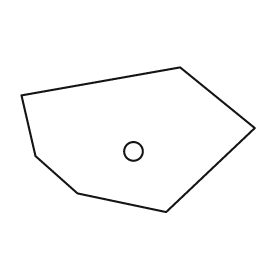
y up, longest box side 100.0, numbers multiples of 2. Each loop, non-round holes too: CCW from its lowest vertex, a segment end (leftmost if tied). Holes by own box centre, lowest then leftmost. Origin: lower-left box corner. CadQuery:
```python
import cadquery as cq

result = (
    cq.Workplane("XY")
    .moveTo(62.0, 0.0)
    .lineTo(100.0, 36.0)
    .lineTo(68.0, 62.0)
    .lineTo(0.0, 50.0)
    .lineTo(6.0, 24.0)
    .lineTo(24.0, 8.0)
    .close()
    .moveTo(48.0, 26.0)
    .circle(4.0)
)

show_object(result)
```